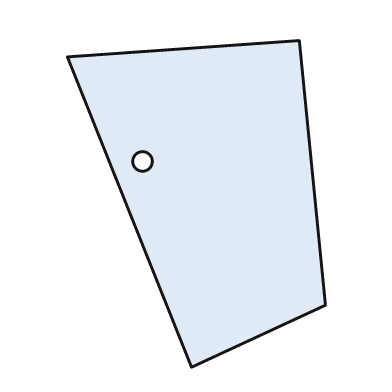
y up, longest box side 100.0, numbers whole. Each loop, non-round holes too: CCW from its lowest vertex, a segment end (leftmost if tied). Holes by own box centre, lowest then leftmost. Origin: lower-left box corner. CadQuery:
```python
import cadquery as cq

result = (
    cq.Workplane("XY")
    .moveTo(38.0, 0.0)
    .lineTo(79.0, 19.0)
    .lineTo(71.0, 100.0)
    .lineTo(0.0, 95.0)
    .close()
    .moveTo(23.0, 63.0)
    .circle(3.0)
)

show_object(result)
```